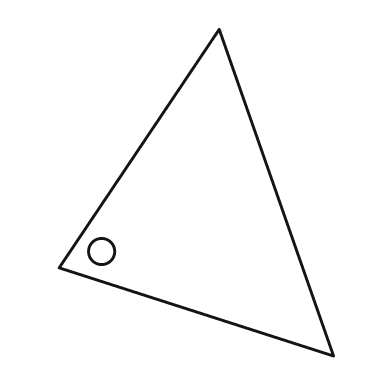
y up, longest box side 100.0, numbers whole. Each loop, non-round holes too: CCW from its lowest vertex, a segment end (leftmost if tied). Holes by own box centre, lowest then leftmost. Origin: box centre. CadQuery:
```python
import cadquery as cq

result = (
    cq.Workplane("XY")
    .moveTo(42.0, -50.0)
    .lineTo(7.0, 50.0)
    .lineTo(-42.0, -23.0)
    .close()
    .moveTo(-29.0, -18.0)
    .circle(4.0)
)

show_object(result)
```